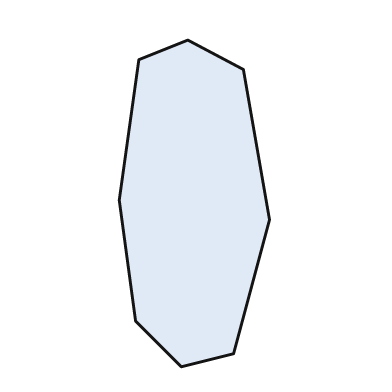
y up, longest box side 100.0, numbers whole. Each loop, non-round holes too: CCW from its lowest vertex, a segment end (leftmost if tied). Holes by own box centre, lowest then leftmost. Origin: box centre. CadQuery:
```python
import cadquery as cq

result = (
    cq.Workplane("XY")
    .moveTo(-4.0, -50.0)
    .lineTo(12.0, -46.0)
    .lineTo(23.0, -5.0)
    .lineTo(15.0, 41.0)
    .lineTo(-2.0, 50.0)
    .lineTo(-17.0, 44.0)
    .lineTo(-23.0, 1.0)
    .lineTo(-18.0, -36.0)
    .close()
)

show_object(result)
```